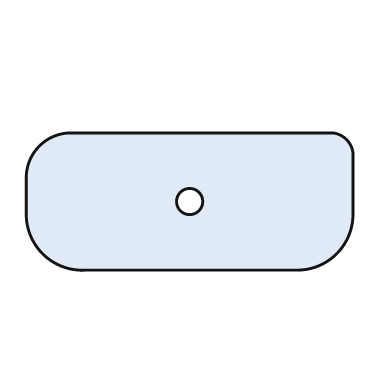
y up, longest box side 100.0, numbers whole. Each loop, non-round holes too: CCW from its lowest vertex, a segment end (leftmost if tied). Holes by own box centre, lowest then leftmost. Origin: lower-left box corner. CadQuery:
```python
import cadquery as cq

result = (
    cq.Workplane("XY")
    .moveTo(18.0, 0.0)
    .lineTo(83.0, 0.0)
    .threePointArc((95.0, 5.0), (100.0, 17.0))
    .lineTo(100.0, 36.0)
    .threePointArc((98.0, 40.0), (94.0, 42.0))
    .lineTo(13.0, 42.0)
    .threePointArc((4.0, 38.0), (0.0, 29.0))
    .lineTo(0.0, 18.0)
    .threePointArc((5.0, 5.0), (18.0, 0.0))
    .close()
    .moveTo(50.0, 21.0)
    .circle(4.0)
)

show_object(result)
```